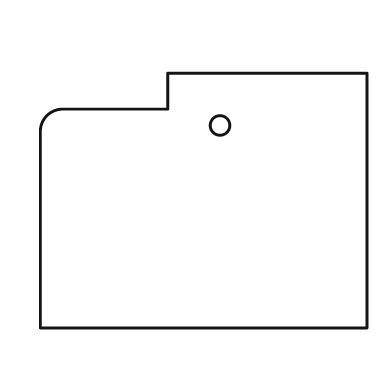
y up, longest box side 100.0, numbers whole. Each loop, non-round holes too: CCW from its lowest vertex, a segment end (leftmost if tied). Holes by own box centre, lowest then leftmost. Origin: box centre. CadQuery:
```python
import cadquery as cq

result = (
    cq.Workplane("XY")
    .moveTo(-50.0, -39.0)
    .lineTo(50.0, -39.0)
    .lineTo(50.0, 39.0)
    .lineTo(-11.0, 39.0)
    .lineTo(-11.0, 28.0)
    .lineTo(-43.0, 28.0)
    .threePointArc((-48.0, 26.0), (-50.0, 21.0))
    .close()
    .moveTo(5.0, 23.0)
    .circle(3.0)
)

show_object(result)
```